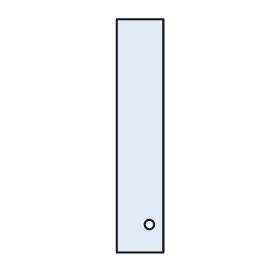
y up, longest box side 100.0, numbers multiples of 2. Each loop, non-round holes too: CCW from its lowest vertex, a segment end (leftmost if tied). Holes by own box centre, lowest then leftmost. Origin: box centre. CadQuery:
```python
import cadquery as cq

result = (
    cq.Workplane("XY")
    .moveTo(-10.0, -50.0)
    .lineTo(10.0, -50.0)
    .lineTo(10.0, 50.0)
    .lineTo(-10.0, 50.0)
    .close()
    .moveTo(4.0, -38.0)
    .circle(2.0)
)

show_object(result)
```